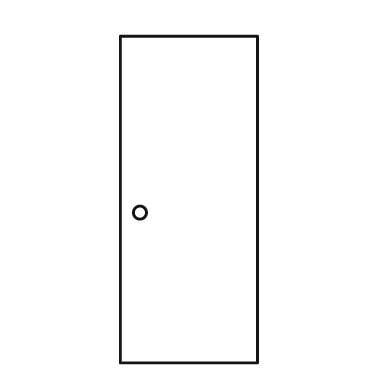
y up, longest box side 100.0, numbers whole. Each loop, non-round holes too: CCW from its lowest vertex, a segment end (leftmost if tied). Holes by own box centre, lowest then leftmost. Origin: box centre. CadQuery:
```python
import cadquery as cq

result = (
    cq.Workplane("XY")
    .moveTo(-21.0, -50.0)
    .lineTo(21.0, -50.0)
    .lineTo(21.0, 50.0)
    .lineTo(-21.0, 50.0)
    .close()
    .moveTo(-15.0, -4.0)
    .circle(2.0)
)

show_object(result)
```